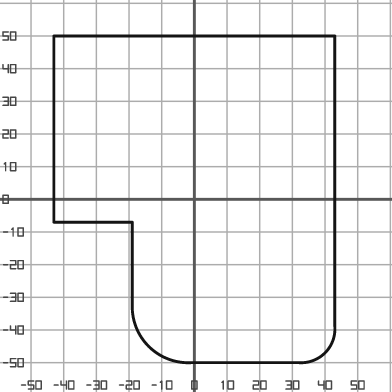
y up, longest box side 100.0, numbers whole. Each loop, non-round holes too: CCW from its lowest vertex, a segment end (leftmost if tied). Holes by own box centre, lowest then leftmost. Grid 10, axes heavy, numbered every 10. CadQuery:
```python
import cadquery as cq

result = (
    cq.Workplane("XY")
    .moveTo(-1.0, -50.0)
    .lineTo(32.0, -50.0)
    .threePointArc((40.0, -47.0), (43.0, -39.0))
    .lineTo(43.0, 50.0)
    .lineTo(-43.0, 50.0)
    .lineTo(-43.0, -7.0)
    .lineTo(-19.0, -7.0)
    .lineTo(-19.0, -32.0)
    .threePointArc((-14.0, -45.0), (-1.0, -50.0))
    .close()
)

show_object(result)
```